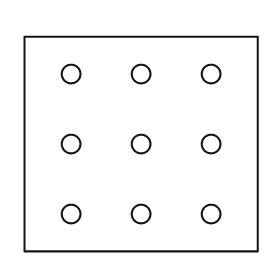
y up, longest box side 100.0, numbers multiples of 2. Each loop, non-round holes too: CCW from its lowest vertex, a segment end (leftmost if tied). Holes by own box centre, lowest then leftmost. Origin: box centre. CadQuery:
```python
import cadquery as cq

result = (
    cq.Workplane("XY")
    .moveTo(-50.0, -46.0)
    .lineTo(50.0, -46.0)
    .lineTo(50.0, 46.0)
    .lineTo(-50.0, 46.0)
    .close()
    .moveTo(-30.0, -30.0)
    .circle(4.0)
    .moveTo(0.0, -30.0)
    .circle(4.0)
    .moveTo(30.0, -30.0)
    .circle(4.0)
    .moveTo(-30.0, 0.0)
    .circle(4.0)
    .moveTo(0.0, 0.0)
    .circle(4.0)
    .moveTo(30.0, 0.0)
    .circle(4.0)
    .moveTo(-30.0, 30.0)
    .circle(4.0)
    .moveTo(0.0, 30.0)
    .circle(4.0)
    .moveTo(30.0, 30.0)
    .circle(4.0)
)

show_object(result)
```